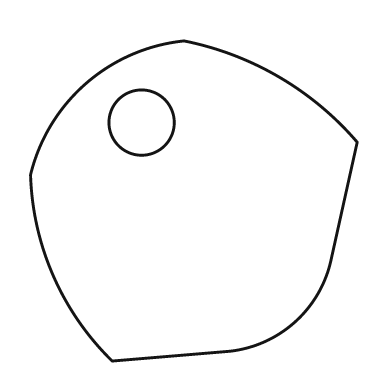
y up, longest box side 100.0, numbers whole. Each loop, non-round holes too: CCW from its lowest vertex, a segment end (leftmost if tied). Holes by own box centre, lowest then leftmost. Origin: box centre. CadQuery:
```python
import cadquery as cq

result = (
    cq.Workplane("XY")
    .moveTo(-25.0, -49.0)
    .lineTo(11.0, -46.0)
    .threePointArc((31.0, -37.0), (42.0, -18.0))
    .lineTo(50.0, 18.0)
    .threePointArc((26.0, 38.0), (-3.0, 49.0))
    .threePointArc((-33.0, 36.0), (-50.0, 8.0))
    .threePointArc((-43.0, -23.0), (-25.0, -49.0))
    .close()
    .moveTo(-16.0, 24.0)
    .circle(10.0)
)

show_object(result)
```